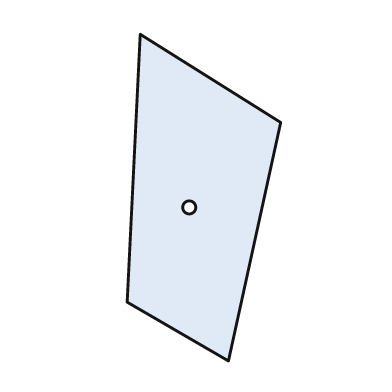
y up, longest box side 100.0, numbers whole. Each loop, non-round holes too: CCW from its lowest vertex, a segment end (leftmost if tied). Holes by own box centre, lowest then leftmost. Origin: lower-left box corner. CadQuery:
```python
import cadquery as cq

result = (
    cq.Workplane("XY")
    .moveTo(31.0, 0.0)
    .lineTo(47.0, 73.0)
    .lineTo(4.0, 100.0)
    .lineTo(0.0, 18.0)
    .close()
    .moveTo(19.0, 47.0)
    .circle(2.0)
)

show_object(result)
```